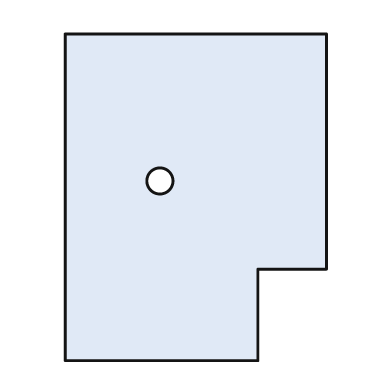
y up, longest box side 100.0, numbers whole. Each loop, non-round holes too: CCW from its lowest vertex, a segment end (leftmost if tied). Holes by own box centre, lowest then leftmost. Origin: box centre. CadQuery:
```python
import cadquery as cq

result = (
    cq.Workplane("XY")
    .moveTo(-40.0, -50.0)
    .lineTo(19.0, -50.0)
    .lineTo(19.0, -22.0)
    .lineTo(40.0, -22.0)
    .lineTo(40.0, 50.0)
    .lineTo(-40.0, 50.0)
    .close()
    .moveTo(-11.0, 5.0)
    .circle(4.0)
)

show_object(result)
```